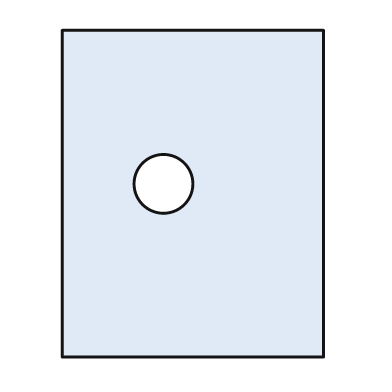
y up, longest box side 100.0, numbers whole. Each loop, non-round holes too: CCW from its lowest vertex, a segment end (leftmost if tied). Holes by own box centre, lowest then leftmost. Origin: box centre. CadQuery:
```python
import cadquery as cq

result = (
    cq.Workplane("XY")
    .moveTo(-40.0, -50.0)
    .lineTo(40.0, -50.0)
    .lineTo(40.0, 50.0)
    .lineTo(-40.0, 50.0)
    .close()
    .moveTo(-9.0, 3.0)
    .circle(9.0)
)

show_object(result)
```